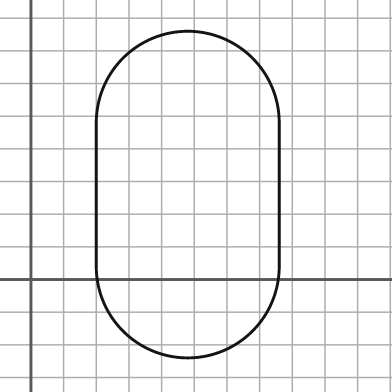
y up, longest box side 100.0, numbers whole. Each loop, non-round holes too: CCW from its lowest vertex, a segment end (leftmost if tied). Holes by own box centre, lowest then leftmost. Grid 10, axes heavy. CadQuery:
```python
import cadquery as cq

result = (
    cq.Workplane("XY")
    .moveTo(20.0, 4.0)
    .threePointArc((48.0, -24.0), (76.0, 4.0))
    .lineTo(76.0, 48.0)
    .threePointArc((48.0, 76.0), (20.0, 48.0))
    .close()
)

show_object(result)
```